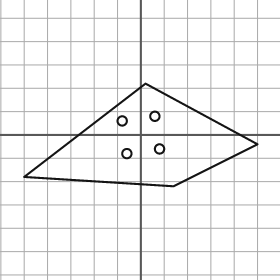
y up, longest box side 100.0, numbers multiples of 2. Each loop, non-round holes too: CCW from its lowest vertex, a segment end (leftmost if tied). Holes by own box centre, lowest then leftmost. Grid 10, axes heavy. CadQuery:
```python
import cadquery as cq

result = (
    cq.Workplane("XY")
    .moveTo(14.0, -22.0)
    .lineTo(50.0, -4.0)
    .lineTo(2.0, 22.0)
    .lineTo(-50.0, -18.0)
    .close()
    .moveTo(-6.0, -8.0)
    .circle(2.0)
    .moveTo(8.0, -6.0)
    .circle(2.0)
    .moveTo(-8.0, 6.0)
    .circle(2.0)
    .moveTo(6.0, 8.0)
    .circle(2.0)
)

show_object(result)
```